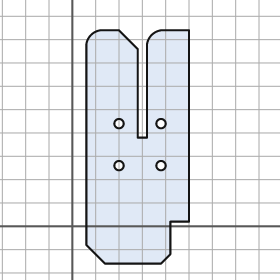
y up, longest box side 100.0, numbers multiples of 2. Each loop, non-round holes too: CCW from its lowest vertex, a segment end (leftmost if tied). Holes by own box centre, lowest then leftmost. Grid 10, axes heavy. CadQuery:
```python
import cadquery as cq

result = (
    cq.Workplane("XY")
    .moveTo(14.0, -16.0)
    .lineTo(38.0, -16.0)
    .lineTo(42.0, -12.0)
    .lineTo(42.0, 2.0)
    .lineTo(50.0, 2.0)
    .lineTo(50.0, 84.0)
    .lineTo(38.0, 84.0)
    .threePointArc((34.0, 82.0), (32.0, 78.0))
    .lineTo(32.0, 38.0)
    .lineTo(28.0, 38.0)
    .lineTo(28.0, 76.0)
    .lineTo(20.0, 84.0)
    .lineTo(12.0, 84.0)
    .threePointArc((8.0, 82.0), (6.0, 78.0))
    .lineTo(6.0, -8.0)
    .close()
    .moveTo(20.0, 26.0)
    .circle(2.0)
    .moveTo(38.0, 26.0)
    .circle(2.0)
    .moveTo(20.0, 44.0)
    .circle(2.0)
    .moveTo(38.0, 44.0)
    .circle(2.0)
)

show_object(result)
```